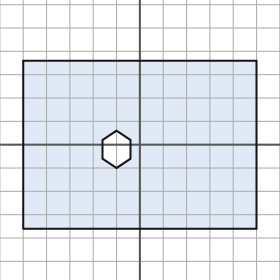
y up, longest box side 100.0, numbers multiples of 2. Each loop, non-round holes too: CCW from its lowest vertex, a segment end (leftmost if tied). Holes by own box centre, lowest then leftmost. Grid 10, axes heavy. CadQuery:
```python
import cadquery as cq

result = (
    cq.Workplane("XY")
    .moveTo(-50.0, -36.0)
    .lineTo(50.0, -36.0)
    .lineTo(50.0, 36.0)
    .lineTo(-50.0, 36.0)
    .close()
    .moveTo(-10.0, -10.0)
    .lineTo(-4.0, -6.0)
    .lineTo(-4.0, 2.0)
    .lineTo(-10.0, 6.0)
    .lineTo(-16.0, 2.0)
    .lineTo(-16.0, -6.0)
    .close()
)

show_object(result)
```